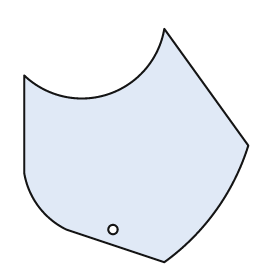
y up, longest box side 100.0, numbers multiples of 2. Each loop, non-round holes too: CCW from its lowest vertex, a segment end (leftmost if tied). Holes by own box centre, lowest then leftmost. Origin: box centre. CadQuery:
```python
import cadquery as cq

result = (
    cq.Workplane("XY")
    .moveTo(12.0, -50.0)
    .threePointArc((34.0, -28.0), (48.0, 0.0))
    .lineTo(12.0, 50.0)
    .threePointArc((-12.0, 22.0), (-48.0, 30.0))
    .lineTo(-48.0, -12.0)
    .threePointArc((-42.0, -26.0), (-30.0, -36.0))
    .close()
    .moveTo(-10.0, -36.0)
    .circle(2.0)
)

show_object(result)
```